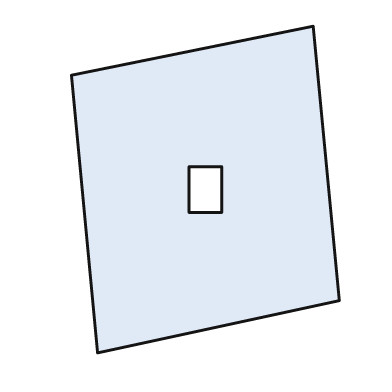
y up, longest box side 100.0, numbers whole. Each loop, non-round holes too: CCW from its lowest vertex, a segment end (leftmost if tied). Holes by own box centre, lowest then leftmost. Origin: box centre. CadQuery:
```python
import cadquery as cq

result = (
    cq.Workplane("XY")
    .moveTo(-33.0, -50.0)
    .lineTo(41.0, -34.0)
    .lineTo(33.0, 50.0)
    .lineTo(-41.0, 35.0)
    .close()
    .moveTo(-5.0, -7.0)
    .lineTo(5.0, -7.0)
    .lineTo(5.0, 7.0)
    .lineTo(-5.0, 7.0)
    .close()
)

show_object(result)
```